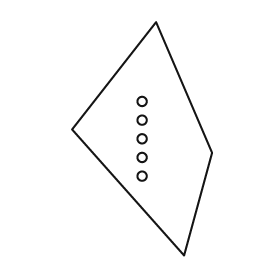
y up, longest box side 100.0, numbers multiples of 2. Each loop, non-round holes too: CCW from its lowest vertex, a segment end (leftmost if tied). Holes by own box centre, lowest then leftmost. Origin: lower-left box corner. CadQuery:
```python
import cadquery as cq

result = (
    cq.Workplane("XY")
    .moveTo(48.0, 0.0)
    .lineTo(60.0, 44.0)
    .lineTo(36.0, 100.0)
    .lineTo(0.0, 54.0)
    .close()
    .moveTo(30.0, 34.0)
    .circle(2.0)
    .moveTo(30.0, 42.0)
    .circle(2.0)
    .moveTo(30.0, 50.0)
    .circle(2.0)
    .moveTo(30.0, 58.0)
    .circle(2.0)
    .moveTo(30.0, 66.0)
    .circle(2.0)
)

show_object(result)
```